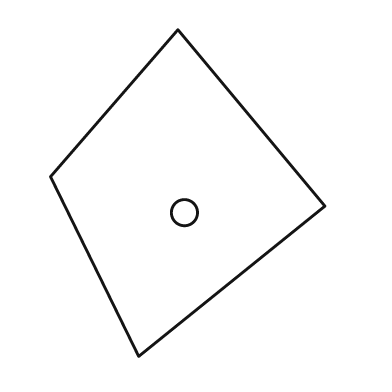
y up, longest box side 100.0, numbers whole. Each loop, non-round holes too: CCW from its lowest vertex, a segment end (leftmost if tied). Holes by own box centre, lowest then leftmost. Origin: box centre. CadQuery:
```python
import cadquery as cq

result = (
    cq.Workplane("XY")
    .moveTo(-15.0, -50.0)
    .lineTo(42.0, -4.0)
    .lineTo(-3.0, 50.0)
    .lineTo(-42.0, 5.0)
    .close()
    .moveTo(-1.0, -6.0)
    .circle(4.0)
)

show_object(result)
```